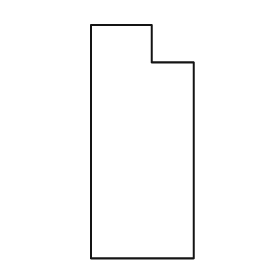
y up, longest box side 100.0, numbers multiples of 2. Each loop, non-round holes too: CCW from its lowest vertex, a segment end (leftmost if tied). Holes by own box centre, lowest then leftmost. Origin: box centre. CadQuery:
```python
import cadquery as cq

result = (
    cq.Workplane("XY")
    .moveTo(-22.0, -50.0)
    .lineTo(22.0, -50.0)
    .lineTo(22.0, 34.0)
    .lineTo(4.0, 34.0)
    .lineTo(4.0, 50.0)
    .lineTo(-22.0, 50.0)
    .close()
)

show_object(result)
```